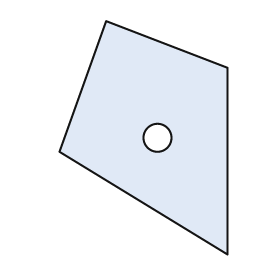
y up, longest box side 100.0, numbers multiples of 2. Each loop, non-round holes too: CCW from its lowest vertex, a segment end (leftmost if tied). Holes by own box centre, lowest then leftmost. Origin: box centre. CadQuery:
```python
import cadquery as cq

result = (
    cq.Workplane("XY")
    .moveTo(36.0, -50.0)
    .lineTo(36.0, 30.0)
    .lineTo(-16.0, 50.0)
    .lineTo(-36.0, -6.0)
    .close()
    .moveTo(6.0, 0.0)
    .circle(6.0)
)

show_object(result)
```